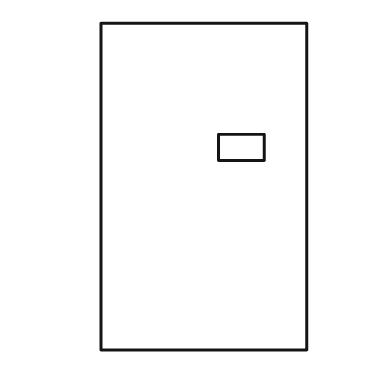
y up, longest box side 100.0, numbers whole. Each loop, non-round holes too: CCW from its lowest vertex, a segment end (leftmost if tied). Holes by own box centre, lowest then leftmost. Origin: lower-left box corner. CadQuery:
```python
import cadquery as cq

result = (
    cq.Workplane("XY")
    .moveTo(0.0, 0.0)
    .lineTo(63.0, 0.0)
    .lineTo(63.0, 100.0)
    .lineTo(0.0, 100.0)
    .close()
    .moveTo(36.0, 58.0)
    .lineTo(50.0, 58.0)
    .lineTo(50.0, 66.0)
    .lineTo(36.0, 66.0)
    .close()
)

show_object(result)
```